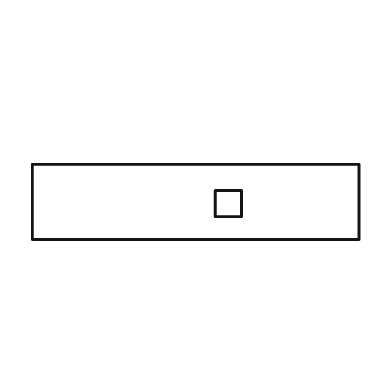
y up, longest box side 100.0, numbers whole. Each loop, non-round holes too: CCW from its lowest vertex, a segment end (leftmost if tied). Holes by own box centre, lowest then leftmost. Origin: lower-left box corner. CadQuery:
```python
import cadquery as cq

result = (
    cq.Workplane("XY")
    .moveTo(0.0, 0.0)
    .lineTo(100.0, 0.0)
    .lineTo(100.0, 23.0)
    .lineTo(0.0, 23.0)
    .close()
    .moveTo(56.0, 7.0)
    .lineTo(64.0, 7.0)
    .lineTo(64.0, 15.0)
    .lineTo(56.0, 15.0)
    .close()
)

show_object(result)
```